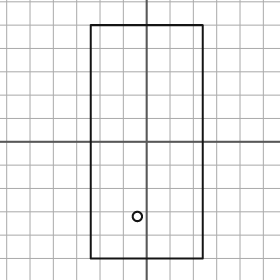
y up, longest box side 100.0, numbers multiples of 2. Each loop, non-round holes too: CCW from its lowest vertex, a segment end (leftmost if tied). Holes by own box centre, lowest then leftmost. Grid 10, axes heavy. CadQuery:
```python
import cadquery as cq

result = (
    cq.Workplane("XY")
    .moveTo(-24.0, -50.0)
    .lineTo(24.0, -50.0)
    .lineTo(24.0, 50.0)
    .lineTo(-24.0, 50.0)
    .close()
    .moveTo(-4.0, -32.0)
    .circle(2.0)
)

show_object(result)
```